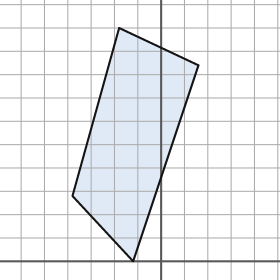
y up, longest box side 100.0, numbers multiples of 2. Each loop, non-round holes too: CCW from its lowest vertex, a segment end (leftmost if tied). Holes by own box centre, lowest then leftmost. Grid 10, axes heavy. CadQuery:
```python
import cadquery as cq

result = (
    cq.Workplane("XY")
    .moveTo(-12.0, 0.0)
    .lineTo(16.0, 84.0)
    .lineTo(-18.0, 100.0)
    .lineTo(-38.0, 28.0)
    .close()
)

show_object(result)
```